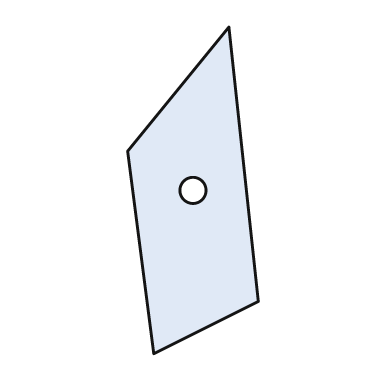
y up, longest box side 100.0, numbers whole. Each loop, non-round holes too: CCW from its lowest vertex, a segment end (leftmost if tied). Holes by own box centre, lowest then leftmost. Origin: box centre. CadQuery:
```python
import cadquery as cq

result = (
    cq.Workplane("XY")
    .moveTo(-12.0, -50.0)
    .lineTo(20.0, -34.0)
    .lineTo(11.0, 50.0)
    .lineTo(-20.0, 12.0)
    .close()
    .moveTo(0.0, 0.0)
    .circle(4.0)
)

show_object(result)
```